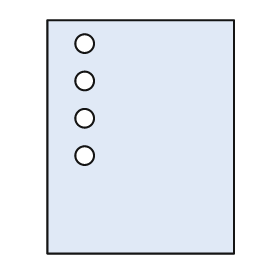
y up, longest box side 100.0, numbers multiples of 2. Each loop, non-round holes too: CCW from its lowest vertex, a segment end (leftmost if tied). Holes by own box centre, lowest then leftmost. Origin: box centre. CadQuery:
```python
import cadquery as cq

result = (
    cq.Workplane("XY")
    .moveTo(-40.0, -50.0)
    .lineTo(40.0, -50.0)
    .lineTo(40.0, 50.0)
    .lineTo(-40.0, 50.0)
    .close()
    .moveTo(-24.0, -8.0)
    .circle(4.0)
    .moveTo(-24.0, 8.0)
    .circle(4.0)
    .moveTo(-24.0, 24.0)
    .circle(4.0)
    .moveTo(-24.0, 40.0)
    .circle(4.0)
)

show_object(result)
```